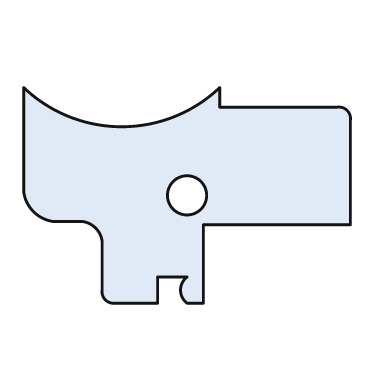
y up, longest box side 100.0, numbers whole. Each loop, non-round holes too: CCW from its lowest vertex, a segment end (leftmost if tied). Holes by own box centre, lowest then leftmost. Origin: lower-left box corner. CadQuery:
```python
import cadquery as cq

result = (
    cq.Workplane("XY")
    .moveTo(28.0, 0.0)
    .lineTo(41.0, 0.0)
    .lineTo(41.0, 8.0)
    .lineTo(50.0, 8.0)
    .threePointArc((48.0, 4.0), (50.0, 0.0))
    .lineTo(55.0, 0.0)
    .lineTo(55.0, 24.0)
    .lineTo(100.0, 24.0)
    .lineTo(100.0, 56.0)
    .threePointArc((99.0, 59.0), (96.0, 60.0))
    .lineTo(60.0, 60.0)
    .lineTo(60.0, 66.0)
    .threePointArc((30.0, 54.0), (0.0, 66.0))
    .lineTo(0.0, 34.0)
    .threePointArc((3.0, 28.0), (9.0, 25.0))
    .lineTo(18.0, 25.0)
    .threePointArc((22.0, 23.0), (24.0, 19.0))
    .lineTo(24.0, 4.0)
    .threePointArc((25.0, 1.0), (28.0, 0.0))
    .close()
    .moveTo(50.0, 33.0)
    .circle(6.0)
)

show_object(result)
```